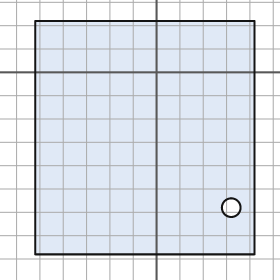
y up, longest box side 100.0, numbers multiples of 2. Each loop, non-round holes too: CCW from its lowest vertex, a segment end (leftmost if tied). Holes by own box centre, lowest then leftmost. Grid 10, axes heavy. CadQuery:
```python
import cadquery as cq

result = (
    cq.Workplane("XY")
    .moveTo(-52.0, -78.0)
    .lineTo(42.0, -78.0)
    .lineTo(42.0, 22.0)
    .lineTo(-52.0, 22.0)
    .close()
    .moveTo(32.0, -58.0)
    .circle(4.0)
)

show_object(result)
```